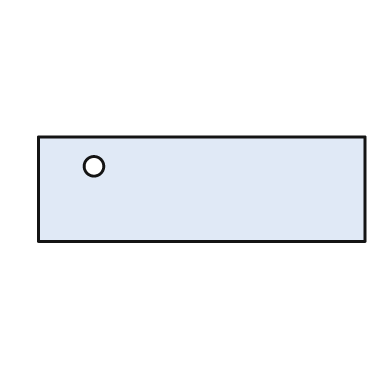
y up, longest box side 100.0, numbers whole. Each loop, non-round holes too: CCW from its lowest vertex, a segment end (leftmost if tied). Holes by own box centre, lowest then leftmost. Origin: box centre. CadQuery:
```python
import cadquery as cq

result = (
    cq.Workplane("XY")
    .moveTo(-50.0, -16.0)
    .lineTo(50.0, -16.0)
    .lineTo(50.0, 16.0)
    .lineTo(-50.0, 16.0)
    .close()
    .moveTo(-33.0, 7.0)
    .circle(3.0)
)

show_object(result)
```